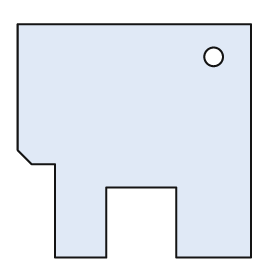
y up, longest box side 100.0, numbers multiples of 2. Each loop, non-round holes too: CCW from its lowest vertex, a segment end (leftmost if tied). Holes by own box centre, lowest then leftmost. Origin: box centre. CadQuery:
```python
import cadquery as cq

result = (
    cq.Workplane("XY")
    .moveTo(-34.0, -50.0)
    .lineTo(-12.0, -50.0)
    .lineTo(-12.0, -20.0)
    .lineTo(18.0, -20.0)
    .lineTo(18.0, -50.0)
    .lineTo(50.0, -50.0)
    .lineTo(50.0, 50.0)
    .lineTo(-50.0, 50.0)
    .lineTo(-50.0, -4.0)
    .lineTo(-44.0, -10.0)
    .lineTo(-34.0, -10.0)
    .close()
    .moveTo(34.0, 36.0)
    .circle(4.0)
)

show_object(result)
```